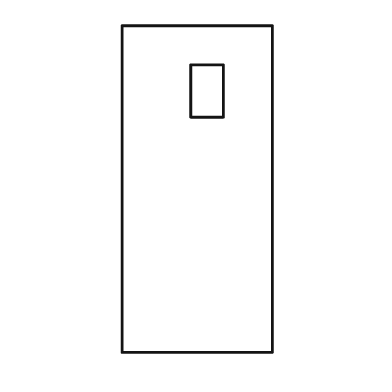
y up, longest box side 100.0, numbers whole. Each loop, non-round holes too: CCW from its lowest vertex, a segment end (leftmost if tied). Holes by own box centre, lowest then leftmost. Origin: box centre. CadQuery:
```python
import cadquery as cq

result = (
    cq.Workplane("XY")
    .moveTo(-23.0, -50.0)
    .lineTo(23.0, -50.0)
    .lineTo(23.0, 50.0)
    .lineTo(-23.0, 50.0)
    .close()
    .moveTo(-2.0, 22.0)
    .lineTo(8.0, 22.0)
    .lineTo(8.0, 38.0)
    .lineTo(-2.0, 38.0)
    .close()
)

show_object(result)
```